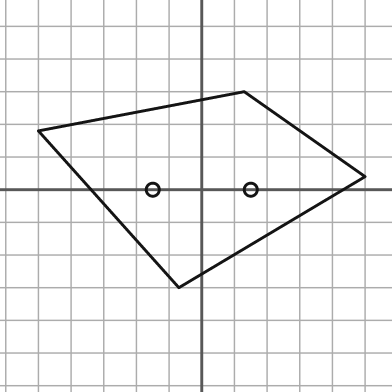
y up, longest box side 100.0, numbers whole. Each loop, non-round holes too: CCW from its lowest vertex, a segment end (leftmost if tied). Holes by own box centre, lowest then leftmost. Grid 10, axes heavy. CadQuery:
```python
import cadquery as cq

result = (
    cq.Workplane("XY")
    .moveTo(-7.0, -30.0)
    .lineTo(50.0, 4.0)
    .lineTo(13.0, 30.0)
    .lineTo(-50.0, 18.0)
    .close()
    .moveTo(-15.0, 0.0)
    .circle(2.0)
    .moveTo(15.0, 0.0)
    .circle(2.0)
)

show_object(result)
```